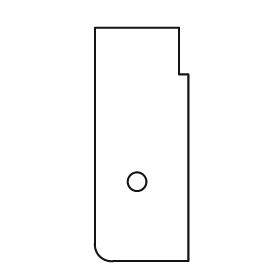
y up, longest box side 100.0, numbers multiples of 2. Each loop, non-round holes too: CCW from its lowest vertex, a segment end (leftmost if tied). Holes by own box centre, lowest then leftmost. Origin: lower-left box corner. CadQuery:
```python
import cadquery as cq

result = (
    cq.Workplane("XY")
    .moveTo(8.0, 0.0)
    .lineTo(40.0, 0.0)
    .lineTo(40.0, 80.0)
    .lineTo(36.0, 80.0)
    .lineTo(36.0, 100.0)
    .lineTo(0.0, 100.0)
    .lineTo(0.0, 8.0)
    .threePointArc((2.0, 2.0), (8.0, 0.0))
    .close()
    .moveTo(18.0, 34.0)
    .circle(4.0)
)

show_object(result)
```